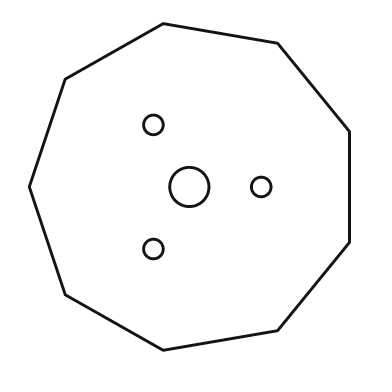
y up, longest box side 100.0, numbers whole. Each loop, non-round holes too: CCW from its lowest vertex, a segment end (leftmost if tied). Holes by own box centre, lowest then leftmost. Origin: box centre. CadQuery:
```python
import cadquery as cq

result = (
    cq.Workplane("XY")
    .moveTo(-8.0, -50.0)
    .lineTo(27.0, -44.0)
    .lineTo(49.0, -17.0)
    .lineTo(49.0, 17.0)
    .lineTo(27.0, 44.0)
    .lineTo(-8.0, 50.0)
    .lineTo(-38.0, 33.0)
    .lineTo(-49.0, 0.0)
    .lineTo(-38.0, -33.0)
    .close()
    .moveTo(-11.0, -19.0)
    .circle(3.0)
    .moveTo(0.0, 0.0)
    .circle(6.0)
    .moveTo(22.0, 0.0)
    .circle(3.0)
    .moveTo(-11.0, 19.0)
    .circle(3.0)
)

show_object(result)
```